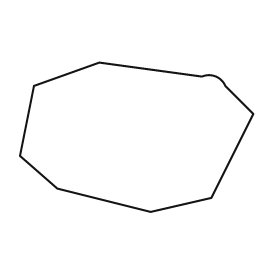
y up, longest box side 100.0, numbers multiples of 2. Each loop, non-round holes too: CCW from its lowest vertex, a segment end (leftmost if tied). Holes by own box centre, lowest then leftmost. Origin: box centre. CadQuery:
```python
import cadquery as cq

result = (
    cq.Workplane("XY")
    .moveTo(6.0, -32.0)
    .lineTo(32.0, -26.0)
    .lineTo(50.0, 10.0)
    .lineTo(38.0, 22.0)
    .threePointArc((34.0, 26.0), (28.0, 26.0))
    .lineTo(-16.0, 32.0)
    .lineTo(-44.0, 22.0)
    .lineTo(-50.0, -8.0)
    .lineTo(-34.0, -22.0)
    .close()
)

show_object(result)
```